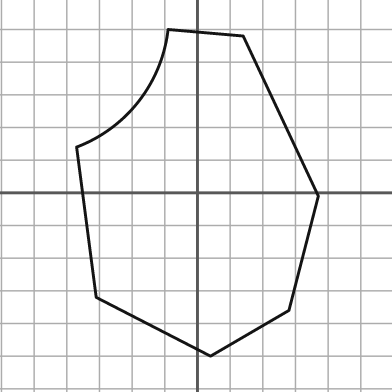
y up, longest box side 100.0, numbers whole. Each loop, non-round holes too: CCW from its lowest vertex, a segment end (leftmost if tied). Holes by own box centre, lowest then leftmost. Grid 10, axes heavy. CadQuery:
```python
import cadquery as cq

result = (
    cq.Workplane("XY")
    .moveTo(4.0, -50.0)
    .lineTo(28.0, -36.0)
    .lineTo(37.0, -1.0)
    .lineTo(14.0, 48.0)
    .lineTo(-9.0, 50.0)
    .threePointArc((-18.0, 28.0), (-37.0, 14.0))
    .lineTo(-31.0, -32.0)
    .close()
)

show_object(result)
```